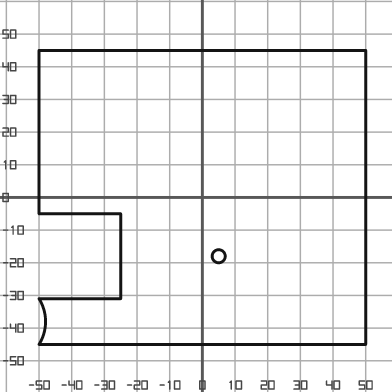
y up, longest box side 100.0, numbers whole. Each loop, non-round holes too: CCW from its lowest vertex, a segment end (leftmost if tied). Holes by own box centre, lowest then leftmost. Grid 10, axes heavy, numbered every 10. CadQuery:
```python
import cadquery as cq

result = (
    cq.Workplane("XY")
    .moveTo(-50.0, -45.0)
    .lineTo(50.0, -45.0)
    .lineTo(50.0, 45.0)
    .lineTo(-50.0, 45.0)
    .lineTo(-50.0, -5.0)
    .lineTo(-25.0, -5.0)
    .lineTo(-25.0, -31.0)
    .lineTo(-50.0, -31.0)
    .threePointArc((-48.0, -38.0), (-50.0, -45.0))
    .close()
    .moveTo(5.0, -18.0)
    .circle(2.0)
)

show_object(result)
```